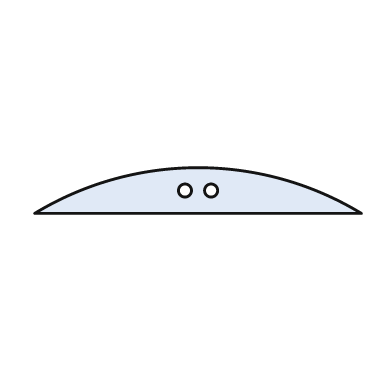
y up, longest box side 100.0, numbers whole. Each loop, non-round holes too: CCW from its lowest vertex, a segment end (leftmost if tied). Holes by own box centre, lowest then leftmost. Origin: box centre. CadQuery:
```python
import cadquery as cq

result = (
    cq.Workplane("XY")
    .moveTo(-50.0, -7.0)
    .lineTo(50.0, -7.0)
    .threePointArc((0.0, 7.0), (-50.0, -7.0))
    .close()
    .moveTo(-4.0, 0.0)
    .circle(2.0)
    .moveTo(4.0, 0.0)
    .circle(2.0)
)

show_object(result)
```